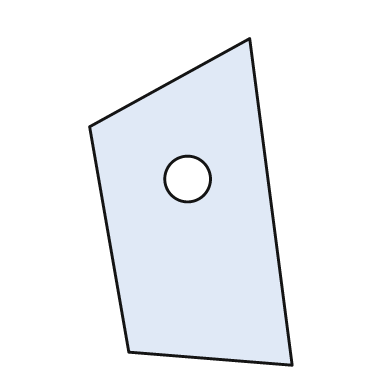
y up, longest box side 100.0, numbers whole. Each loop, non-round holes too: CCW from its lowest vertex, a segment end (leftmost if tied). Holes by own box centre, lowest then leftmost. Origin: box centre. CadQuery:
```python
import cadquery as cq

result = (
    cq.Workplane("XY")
    .moveTo(31.0, -50.0)
    .lineTo(18.0, 50.0)
    .lineTo(-31.0, 23.0)
    .lineTo(-19.0, -46.0)
    .close()
    .moveTo(-1.0, 7.0)
    .circle(7.0)
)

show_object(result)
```